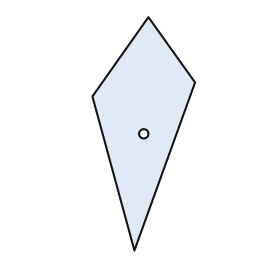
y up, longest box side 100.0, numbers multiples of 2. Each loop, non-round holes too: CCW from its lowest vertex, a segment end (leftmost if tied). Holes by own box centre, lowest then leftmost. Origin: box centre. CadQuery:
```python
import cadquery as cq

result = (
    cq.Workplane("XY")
    .moveTo(-4.0, -50.0)
    .lineTo(22.0, 22.0)
    .lineTo(2.0, 50.0)
    .lineTo(-22.0, 16.0)
    .close()
    .moveTo(0.0, 0.0)
    .circle(2.0)
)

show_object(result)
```